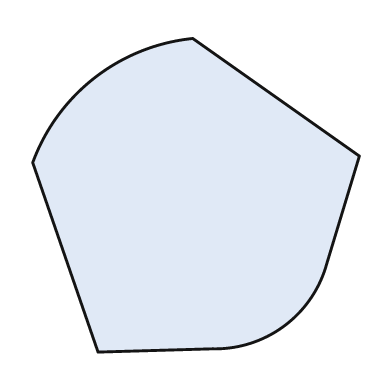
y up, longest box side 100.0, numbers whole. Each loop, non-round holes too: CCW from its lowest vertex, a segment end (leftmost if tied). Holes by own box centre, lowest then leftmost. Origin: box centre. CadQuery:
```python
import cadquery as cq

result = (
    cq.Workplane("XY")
    .moveTo(-30.0, -48.0)
    .lineTo(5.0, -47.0)
    .threePointArc((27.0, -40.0), (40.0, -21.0))
    .lineTo(50.0, 12.0)
    .lineTo(-1.0, 48.0)
    .threePointArc((-31.0, 36.0), (-50.0, 10.0))
    .close()
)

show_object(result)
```